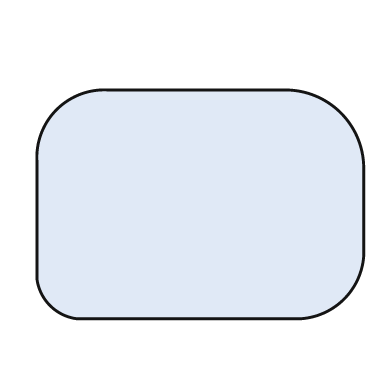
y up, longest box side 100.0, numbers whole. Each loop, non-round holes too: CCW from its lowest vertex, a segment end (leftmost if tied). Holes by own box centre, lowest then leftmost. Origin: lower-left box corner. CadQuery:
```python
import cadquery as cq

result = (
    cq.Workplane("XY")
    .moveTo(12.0, 0.0)
    .lineTo(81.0, 0.0)
    .threePointArc((94.0, 6.0), (100.0, 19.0))
    .lineTo(100.0, 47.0)
    .threePointArc((93.0, 63.0), (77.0, 70.0))
    .lineTo(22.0, 70.0)
    .threePointArc((6.0, 64.0), (0.0, 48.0))
    .lineTo(0.0, 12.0)
    .threePointArc((4.0, 4.0), (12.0, 0.0))
    .close()
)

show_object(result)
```